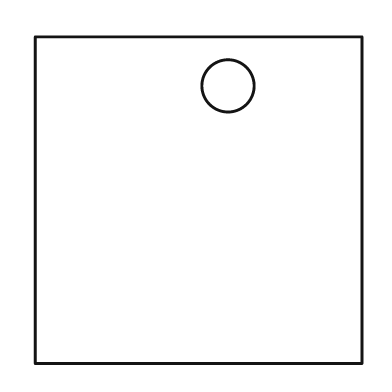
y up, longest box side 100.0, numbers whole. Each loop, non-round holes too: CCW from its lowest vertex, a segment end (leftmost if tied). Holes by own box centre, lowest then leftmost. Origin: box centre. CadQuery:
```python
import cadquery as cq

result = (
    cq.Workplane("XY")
    .moveTo(-50.0, -50.0)
    .lineTo(50.0, -50.0)
    .lineTo(50.0, 50.0)
    .lineTo(-50.0, 50.0)
    .close()
    .moveTo(9.0, 35.0)
    .circle(8.0)
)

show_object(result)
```